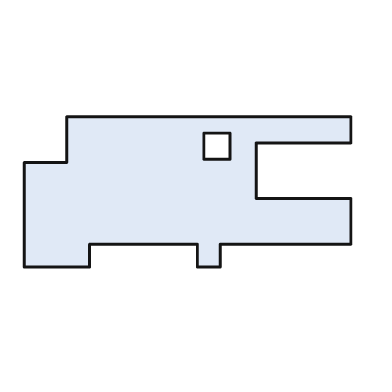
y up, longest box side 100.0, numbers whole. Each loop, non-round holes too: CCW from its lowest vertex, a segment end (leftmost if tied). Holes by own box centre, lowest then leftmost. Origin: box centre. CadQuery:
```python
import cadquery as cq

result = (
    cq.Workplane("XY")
    .moveTo(-50.0, -23.0)
    .lineTo(-30.0, -23.0)
    .lineTo(-30.0, -16.0)
    .lineTo(3.0, -16.0)
    .lineTo(3.0, -23.0)
    .lineTo(10.0, -23.0)
    .lineTo(10.0, -16.0)
    .lineTo(50.0, -16.0)
    .lineTo(50.0, -2.0)
    .lineTo(21.0, -2.0)
    .lineTo(21.0, 15.0)
    .lineTo(50.0, 15.0)
    .lineTo(50.0, 23.0)
    .lineTo(-37.0, 23.0)
    .lineTo(-37.0, 9.0)
    .lineTo(-50.0, 9.0)
    .close()
    .moveTo(5.0, 10.0)
    .lineTo(13.0, 10.0)
    .lineTo(13.0, 18.0)
    .lineTo(5.0, 18.0)
    .close()
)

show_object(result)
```